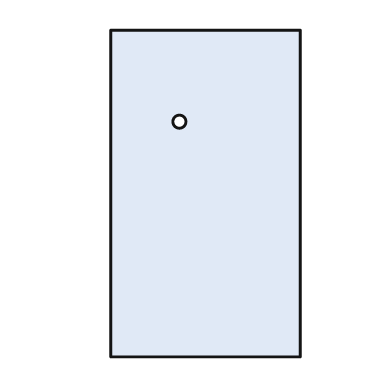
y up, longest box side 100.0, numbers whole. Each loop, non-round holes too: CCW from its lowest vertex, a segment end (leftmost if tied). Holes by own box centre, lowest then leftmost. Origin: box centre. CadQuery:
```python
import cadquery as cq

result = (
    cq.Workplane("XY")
    .moveTo(-29.0, -50.0)
    .lineTo(29.0, -50.0)
    .lineTo(29.0, 50.0)
    .lineTo(-29.0, 50.0)
    .close()
    .moveTo(-8.0, 22.0)
    .circle(2.0)
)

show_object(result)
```